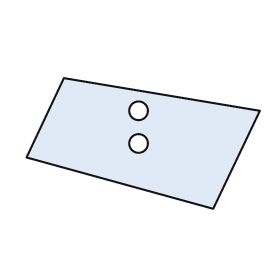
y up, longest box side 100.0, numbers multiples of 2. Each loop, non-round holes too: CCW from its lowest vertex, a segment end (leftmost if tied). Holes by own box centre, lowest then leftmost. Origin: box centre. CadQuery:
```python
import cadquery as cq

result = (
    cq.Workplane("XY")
    .moveTo(30.0, -28.0)
    .lineTo(50.0, 14.0)
    .lineTo(-34.0, 28.0)
    .lineTo(-50.0, -6.0)
    .close()
    .moveTo(-2.0, 0.0)
    .circle(4.0)
    .moveTo(-2.0, 14.0)
    .circle(4.0)
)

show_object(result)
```